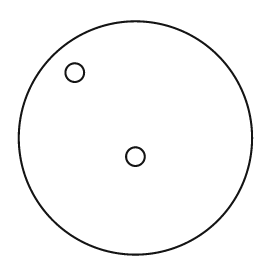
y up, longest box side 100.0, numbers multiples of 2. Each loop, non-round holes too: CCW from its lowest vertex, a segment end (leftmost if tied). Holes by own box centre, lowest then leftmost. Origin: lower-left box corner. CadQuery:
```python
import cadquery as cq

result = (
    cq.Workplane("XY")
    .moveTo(50.0, 50.0)
    .circle(50.0)
    .moveTo(50.0, 42.0)
    .circle(4.0)
    .moveTo(24.0, 78.0)
    .circle(4.0)
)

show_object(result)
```